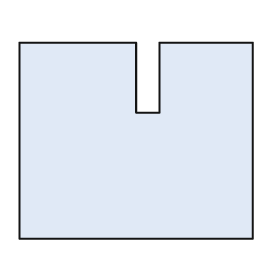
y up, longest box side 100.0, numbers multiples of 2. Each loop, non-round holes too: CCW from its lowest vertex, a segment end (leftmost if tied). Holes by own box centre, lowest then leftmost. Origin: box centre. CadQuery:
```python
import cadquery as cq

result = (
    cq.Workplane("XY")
    .moveTo(-50.0, -42.0)
    .lineTo(50.0, -42.0)
    .lineTo(50.0, 42.0)
    .lineTo(10.0, 42.0)
    .lineTo(10.0, 12.0)
    .lineTo(0.0, 12.0)
    .lineTo(0.0, 42.0)
    .lineTo(-50.0, 42.0)
    .close()
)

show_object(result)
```